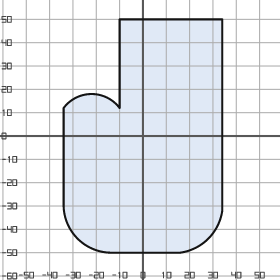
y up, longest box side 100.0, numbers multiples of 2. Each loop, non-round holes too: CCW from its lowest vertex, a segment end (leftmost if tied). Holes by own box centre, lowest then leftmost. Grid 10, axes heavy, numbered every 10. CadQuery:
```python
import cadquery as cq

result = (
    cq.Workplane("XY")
    .moveTo(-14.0, -50.0)
    .lineTo(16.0, -50.0)
    .threePointArc((28.0, -44.0), (34.0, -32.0))
    .lineTo(34.0, 50.0)
    .lineTo(-10.0, 50.0)
    .lineTo(-10.0, 12.0)
    .threePointArc((-22.0, 18.0), (-34.0, 12.0))
    .lineTo(-34.0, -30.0)
    .threePointArc((-28.0, -44.0), (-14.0, -50.0))
    .close()
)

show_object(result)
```